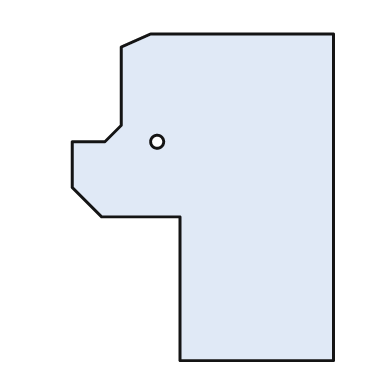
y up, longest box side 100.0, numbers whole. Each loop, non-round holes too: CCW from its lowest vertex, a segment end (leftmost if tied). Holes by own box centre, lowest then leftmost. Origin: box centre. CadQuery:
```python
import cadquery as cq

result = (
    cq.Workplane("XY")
    .moveTo(-7.0, -50.0)
    .lineTo(40.0, -50.0)
    .lineTo(40.0, 50.0)
    .lineTo(-16.0, 50.0)
    .lineTo(-25.0, 46.0)
    .lineTo(-25.0, 22.0)
    .lineTo(-30.0, 17.0)
    .lineTo(-40.0, 17.0)
    .lineTo(-40.0, 3.0)
    .lineTo(-31.0, -6.0)
    .lineTo(-7.0, -6.0)
    .close()
    .moveTo(-14.0, 17.0)
    .circle(2.0)
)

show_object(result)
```